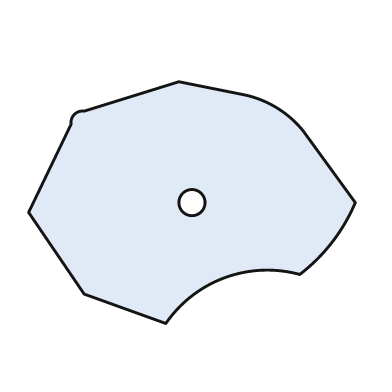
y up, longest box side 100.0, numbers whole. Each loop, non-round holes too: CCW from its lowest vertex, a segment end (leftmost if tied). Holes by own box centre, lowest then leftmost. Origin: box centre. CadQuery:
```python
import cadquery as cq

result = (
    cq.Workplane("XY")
    .moveTo(-8.0, -37.0)
    .threePointArc((10.0, -23.0), (33.0, -22.0))
    .threePointArc((43.0, -12.0), (50.0, 0.0))
    .lineTo(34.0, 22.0)
    .threePointArc((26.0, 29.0), (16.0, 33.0))
    .lineTo(-4.0, 37.0)
    .lineTo(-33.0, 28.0)
    .threePointArc((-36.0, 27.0), (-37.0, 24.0))
    .lineTo(-50.0, -3.0)
    .lineTo(-33.0, -28.0)
    .close()
    .moveTo(0.0, 0.0)
    .circle(4.0)
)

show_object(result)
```